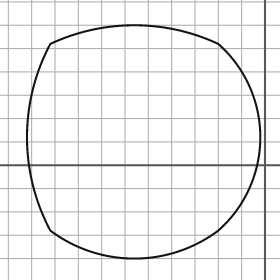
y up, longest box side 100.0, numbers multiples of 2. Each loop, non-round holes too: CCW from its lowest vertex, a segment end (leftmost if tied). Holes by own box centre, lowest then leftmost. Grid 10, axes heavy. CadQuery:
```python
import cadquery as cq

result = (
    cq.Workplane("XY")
    .moveTo(-92.0, -28.0)
    .threePointArc((-56.0, -40.0), (-20.0, -28.0))
    .threePointArc((-2.0, 12.0), (-20.0, 52.0))
    .threePointArc((-56.0, 60.0), (-92.0, 52.0))
    .threePointArc((-102.0, 12.0), (-92.0, -28.0))
    .close()
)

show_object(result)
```